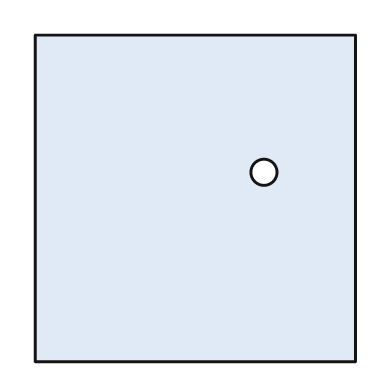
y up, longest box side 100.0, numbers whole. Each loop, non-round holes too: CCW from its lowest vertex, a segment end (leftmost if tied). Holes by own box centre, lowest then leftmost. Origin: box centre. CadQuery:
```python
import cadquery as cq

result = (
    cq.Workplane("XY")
    .moveTo(-49.0, -50.0)
    .lineTo(49.0, -50.0)
    .lineTo(49.0, 50.0)
    .lineTo(-49.0, 50.0)
    .close()
    .moveTo(21.0, 8.0)
    .circle(4.0)
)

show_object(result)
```